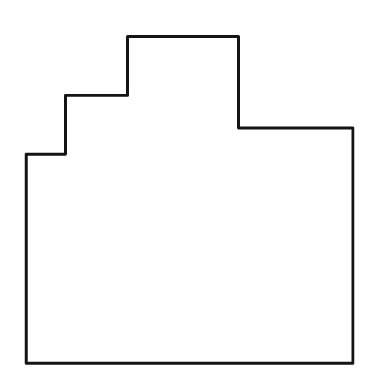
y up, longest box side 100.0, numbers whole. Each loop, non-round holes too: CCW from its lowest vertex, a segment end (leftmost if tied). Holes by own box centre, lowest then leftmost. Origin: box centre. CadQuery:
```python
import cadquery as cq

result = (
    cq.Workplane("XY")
    .moveTo(-50.0, -50.0)
    .lineTo(50.0, -50.0)
    .lineTo(50.0, 22.0)
    .lineTo(15.0, 22.0)
    .lineTo(15.0, 50.0)
    .lineTo(-19.0, 50.0)
    .lineTo(-19.0, 32.0)
    .lineTo(-38.0, 32.0)
    .lineTo(-38.0, 14.0)
    .lineTo(-50.0, 14.0)
    .close()
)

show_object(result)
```